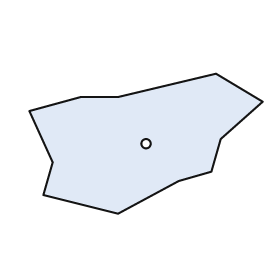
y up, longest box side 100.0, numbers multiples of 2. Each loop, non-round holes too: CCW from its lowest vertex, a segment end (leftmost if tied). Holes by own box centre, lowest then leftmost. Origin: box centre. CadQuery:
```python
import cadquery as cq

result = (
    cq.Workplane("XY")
    .moveTo(-12.0, -30.0)
    .lineTo(14.0, -16.0)
    .lineTo(28.0, -12.0)
    .lineTo(32.0, 2.0)
    .lineTo(50.0, 18.0)
    .lineTo(30.0, 30.0)
    .lineTo(-12.0, 20.0)
    .lineTo(-28.0, 20.0)
    .lineTo(-50.0, 14.0)
    .lineTo(-40.0, -8.0)
    .lineTo(-44.0, -22.0)
    .close()
    .moveTo(0.0, 0.0)
    .circle(2.0)
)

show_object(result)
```